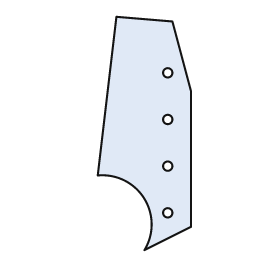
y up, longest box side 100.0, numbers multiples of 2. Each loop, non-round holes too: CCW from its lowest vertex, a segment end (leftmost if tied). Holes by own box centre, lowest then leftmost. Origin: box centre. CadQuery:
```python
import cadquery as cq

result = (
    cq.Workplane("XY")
    .moveTo(0.0, -50.0)
    .lineTo(20.0, -40.0)
    .lineTo(20.0, 18.0)
    .lineTo(12.0, 48.0)
    .lineTo(-12.0, 50.0)
    .lineTo(-20.0, -18.0)
    .threePointArc((0.0, -28.0), (0.0, -50.0))
    .close()
    .moveTo(10.0, -34.0)
    .circle(2.0)
    .moveTo(10.0, -14.0)
    .circle(2.0)
    .moveTo(10.0, 6.0)
    .circle(2.0)
    .moveTo(10.0, 26.0)
    .circle(2.0)
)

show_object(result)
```